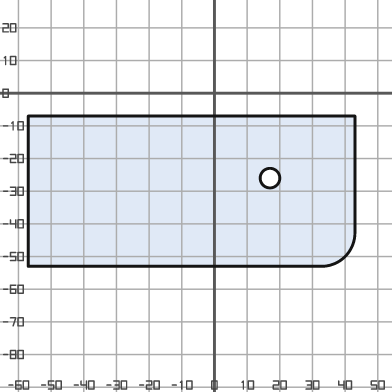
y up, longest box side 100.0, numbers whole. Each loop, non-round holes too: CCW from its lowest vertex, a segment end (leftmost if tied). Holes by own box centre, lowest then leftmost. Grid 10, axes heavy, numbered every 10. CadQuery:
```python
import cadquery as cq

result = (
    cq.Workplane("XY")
    .moveTo(-57.0, -53.0)
    .lineTo(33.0, -53.0)
    .threePointArc((40.0, -50.0), (43.0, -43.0))
    .lineTo(43.0, -7.0)
    .lineTo(-57.0, -7.0)
    .close()
    .moveTo(17.0, -26.0)
    .circle(3.0)
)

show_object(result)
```